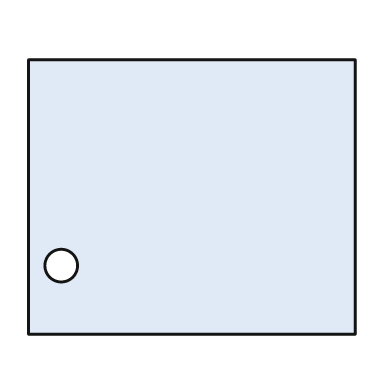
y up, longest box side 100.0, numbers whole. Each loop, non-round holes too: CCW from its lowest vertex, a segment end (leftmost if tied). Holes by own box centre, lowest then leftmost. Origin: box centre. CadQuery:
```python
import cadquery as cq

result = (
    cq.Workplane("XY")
    .moveTo(-50.0, -42.0)
    .lineTo(50.0, -42.0)
    .lineTo(50.0, 42.0)
    .lineTo(-50.0, 42.0)
    .close()
    .moveTo(-40.0, -21.0)
    .circle(5.0)
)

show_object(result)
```